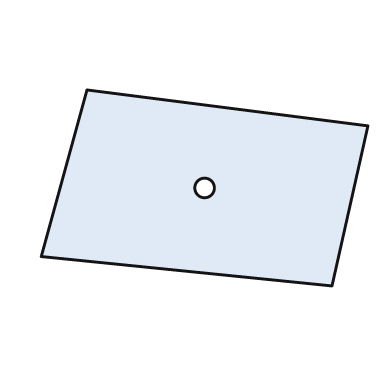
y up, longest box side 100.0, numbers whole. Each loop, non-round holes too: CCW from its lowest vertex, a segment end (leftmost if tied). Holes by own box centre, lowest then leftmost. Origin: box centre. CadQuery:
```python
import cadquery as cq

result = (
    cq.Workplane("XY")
    .moveTo(39.0, -30.0)
    .lineTo(50.0, 19.0)
    .lineTo(-36.0, 30.0)
    .lineTo(-50.0, -21.0)
    .close()
    .moveTo(0.0, 0.0)
    .circle(3.0)
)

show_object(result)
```